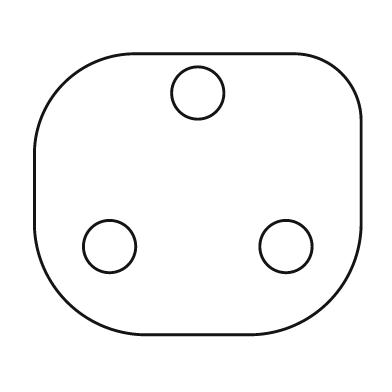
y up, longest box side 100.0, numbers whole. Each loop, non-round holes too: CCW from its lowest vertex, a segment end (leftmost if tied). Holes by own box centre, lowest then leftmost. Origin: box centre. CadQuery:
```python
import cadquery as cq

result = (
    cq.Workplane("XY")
    .moveTo(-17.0, -43.0)
    .lineTo(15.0, -43.0)
    .threePointArc((40.0, -33.0), (50.0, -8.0))
    .lineTo(50.0, 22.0)
    .threePointArc((44.0, 37.0), (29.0, 43.0))
    .lineTo(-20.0, 43.0)
    .threePointArc((-41.0, 34.0), (-50.0, 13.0))
    .lineTo(-50.0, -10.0)
    .threePointArc((-40.0, -33.0), (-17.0, -43.0))
    .close()
    .moveTo(-27.0, -16.0)
    .circle(8.0)
    .moveTo(27.0, -16.0)
    .circle(8.0)
    .moveTo(0.0, 31.0)
    .circle(8.0)
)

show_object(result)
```